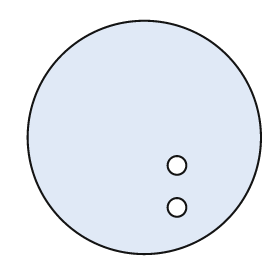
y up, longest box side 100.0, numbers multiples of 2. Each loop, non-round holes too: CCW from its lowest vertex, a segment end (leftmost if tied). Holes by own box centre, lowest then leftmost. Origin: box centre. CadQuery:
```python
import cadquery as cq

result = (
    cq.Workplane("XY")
    .moveTo(0.0, 0.0)
    .circle(50.0)
    .moveTo(14.0, -30.0)
    .circle(4.0)
    .moveTo(14.0, -12.0)
    .circle(4.0)
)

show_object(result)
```